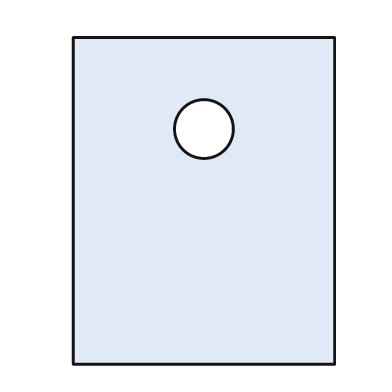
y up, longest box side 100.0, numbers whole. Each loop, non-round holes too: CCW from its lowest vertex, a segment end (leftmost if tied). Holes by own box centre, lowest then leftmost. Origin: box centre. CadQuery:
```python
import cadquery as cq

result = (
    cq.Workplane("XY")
    .moveTo(-40.0, -50.0)
    .lineTo(40.0, -50.0)
    .lineTo(40.0, 50.0)
    .lineTo(-40.0, 50.0)
    .close()
    .moveTo(0.0, 22.0)
    .circle(9.0)
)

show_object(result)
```